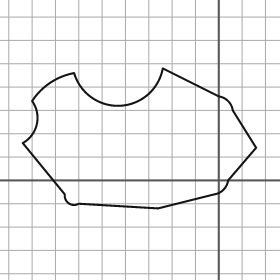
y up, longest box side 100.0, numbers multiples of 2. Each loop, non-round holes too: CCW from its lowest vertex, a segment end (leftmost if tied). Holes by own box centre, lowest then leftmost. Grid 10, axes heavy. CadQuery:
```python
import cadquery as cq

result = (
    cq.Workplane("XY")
    .moveTo(-26.0, -12.0)
    .lineTo(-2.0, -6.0)
    .threePointArc((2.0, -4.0), (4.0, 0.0))
    .lineTo(16.0, 14.0)
    .lineTo(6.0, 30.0)
    .threePointArc((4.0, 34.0), (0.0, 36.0))
    .lineTo(-24.0, 48.0)
    .threePointArc((-42.0, 32.0), (-62.0, 46.0))
    .threePointArc((-72.0, 42.0), (-80.0, 34.0))
    .threePointArc((-78.0, 24.0), (-84.0, 16.0))
    .lineTo(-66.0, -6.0)
    .threePointArc((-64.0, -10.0), (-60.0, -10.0))
    .close()
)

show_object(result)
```